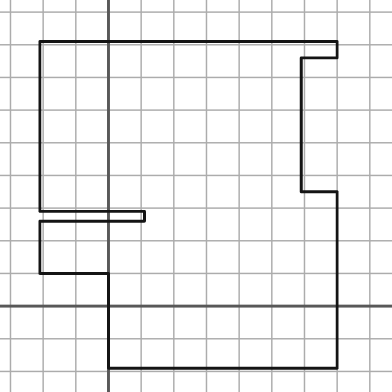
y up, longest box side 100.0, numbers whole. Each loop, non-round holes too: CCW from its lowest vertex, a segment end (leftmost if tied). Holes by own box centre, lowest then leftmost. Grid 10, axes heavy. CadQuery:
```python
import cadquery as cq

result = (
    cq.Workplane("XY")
    .moveTo(0.0, -19.0)
    .lineTo(70.0, -19.0)
    .lineTo(70.0, 35.0)
    .lineTo(59.0, 35.0)
    .lineTo(59.0, 76.0)
    .lineTo(70.0, 76.0)
    .lineTo(70.0, 81.0)
    .lineTo(-21.0, 81.0)
    .lineTo(-21.0, 29.0)
    .lineTo(11.0, 29.0)
    .lineTo(11.0, 26.0)
    .lineTo(-21.0, 26.0)
    .lineTo(-21.0, 10.0)
    .lineTo(0.0, 10.0)
    .close()
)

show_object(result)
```